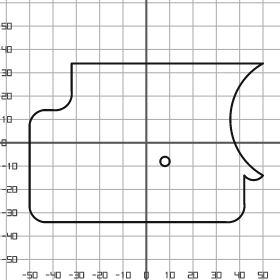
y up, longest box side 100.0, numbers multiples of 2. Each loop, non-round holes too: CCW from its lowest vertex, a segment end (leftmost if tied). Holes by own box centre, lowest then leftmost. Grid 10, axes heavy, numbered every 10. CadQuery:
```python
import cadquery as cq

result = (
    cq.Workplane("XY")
    .moveTo(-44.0, -34.0)
    .lineTo(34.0, -34.0)
    .threePointArc((40.0, -32.0), (42.0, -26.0))
    .lineTo(42.0, -14.0)
    .threePointArc((46.0, -16.0), (50.0, -14.0))
    .threePointArc((36.0, 10.0), (50.0, 34.0))
    .lineTo(-32.0, 34.0)
    .lineTo(-32.0, 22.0)
    .threePointArc((-34.0, 16.0), (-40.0, 14.0))
    .lineTo(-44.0, 14.0)
    .threePointArc((-48.0, 12.0), (-50.0, 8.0))
    .lineTo(-50.0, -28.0)
    .threePointArc((-48.0, -32.0), (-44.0, -34.0))
    .close()
    .moveTo(8.0, -8.0)
    .circle(2.0)
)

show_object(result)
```